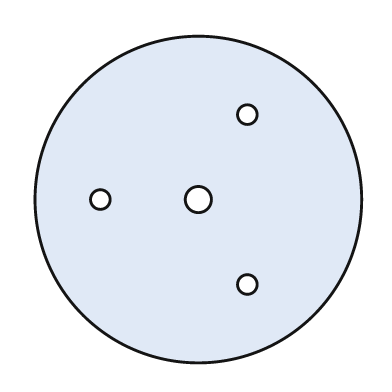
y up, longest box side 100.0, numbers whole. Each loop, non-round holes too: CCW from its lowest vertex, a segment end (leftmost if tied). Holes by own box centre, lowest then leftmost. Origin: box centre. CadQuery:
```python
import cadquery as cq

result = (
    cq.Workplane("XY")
    .moveTo(0.0, 0.0)
    .circle(50.0)
    .moveTo(15.0, -26.0)
    .circle(3.0)
    .moveTo(-30.0, 0.0)
    .circle(3.0)
    .moveTo(0.0, 0.0)
    .circle(4.0)
    .moveTo(15.0, 26.0)
    .circle(3.0)
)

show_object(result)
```